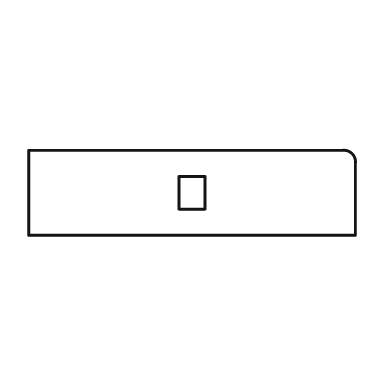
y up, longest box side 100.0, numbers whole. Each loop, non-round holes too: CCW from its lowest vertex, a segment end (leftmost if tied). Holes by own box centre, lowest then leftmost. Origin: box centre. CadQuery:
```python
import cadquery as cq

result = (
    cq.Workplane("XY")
    .moveTo(-50.0, -13.0)
    .lineTo(50.0, -13.0)
    .lineTo(50.0, 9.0)
    .threePointArc((49.0, 12.0), (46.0, 13.0))
    .lineTo(-50.0, 13.0)
    .close()
    .moveTo(-4.0, -5.0)
    .lineTo(4.0, -5.0)
    .lineTo(4.0, 5.0)
    .lineTo(-4.0, 5.0)
    .close()
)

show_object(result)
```